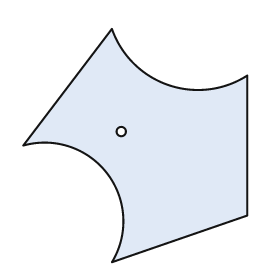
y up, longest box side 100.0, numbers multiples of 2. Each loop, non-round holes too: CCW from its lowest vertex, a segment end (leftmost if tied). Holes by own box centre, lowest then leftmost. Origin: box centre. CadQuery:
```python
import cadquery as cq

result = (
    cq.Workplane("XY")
    .moveTo(-10.0, -50.0)
    .lineTo(48.0, -30.0)
    .lineTo(48.0, 30.0)
    .threePointArc((14.0, 26.0), (-10.0, 50.0))
    .lineTo(-48.0, 0.0)
    .threePointArc((-12.0, -12.0), (-10.0, -50.0))
    .close()
    .moveTo(-6.0, 6.0)
    .circle(2.0)
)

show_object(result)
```